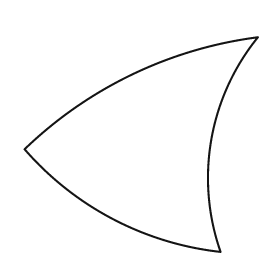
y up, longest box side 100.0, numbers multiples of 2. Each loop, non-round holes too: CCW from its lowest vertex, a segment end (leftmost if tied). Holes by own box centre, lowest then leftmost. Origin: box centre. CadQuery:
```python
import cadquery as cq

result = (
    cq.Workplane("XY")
    .moveTo(34.0, -46.0)
    .threePointArc((30.0, 2.0), (50.0, 46.0))
    .threePointArc((-4.0, 30.0), (-50.0, -2.0))
    .threePointArc((-12.0, -32.0), (34.0, -46.0))
    .close()
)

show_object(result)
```